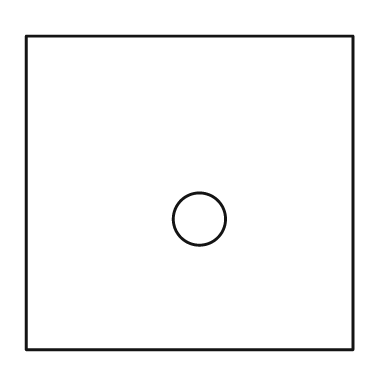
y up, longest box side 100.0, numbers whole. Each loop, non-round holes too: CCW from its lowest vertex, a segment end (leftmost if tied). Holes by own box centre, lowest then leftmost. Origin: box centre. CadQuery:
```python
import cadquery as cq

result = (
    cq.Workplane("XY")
    .moveTo(-50.0, -48.0)
    .lineTo(50.0, -48.0)
    .lineTo(50.0, 48.0)
    .lineTo(-50.0, 48.0)
    .close()
    .moveTo(3.0, -8.0)
    .circle(8.0)
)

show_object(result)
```